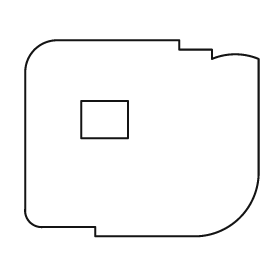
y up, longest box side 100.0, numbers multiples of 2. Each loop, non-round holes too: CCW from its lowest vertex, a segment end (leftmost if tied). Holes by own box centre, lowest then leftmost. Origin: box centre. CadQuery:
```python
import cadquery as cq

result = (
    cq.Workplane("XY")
    .moveTo(-20.0, -42.0)
    .lineTo(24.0, -42.0)
    .threePointArc((42.0, -34.0), (50.0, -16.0))
    .lineTo(50.0, 34.0)
    .threePointArc((40.0, 36.0), (30.0, 34.0))
    .lineTo(30.0, 38.0)
    .lineTo(16.0, 38.0)
    .lineTo(16.0, 42.0)
    .lineTo(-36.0, 42.0)
    .threePointArc((-46.0, 38.0), (-50.0, 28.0))
    .lineTo(-50.0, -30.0)
    .threePointArc((-48.0, -36.0), (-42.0, -38.0))
    .lineTo(-20.0, -38.0)
    .close()
    .moveTo(-26.0, 0.0)
    .lineTo(-6.0, 0.0)
    .lineTo(-6.0, 16.0)
    .lineTo(-26.0, 16.0)
    .close()
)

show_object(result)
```